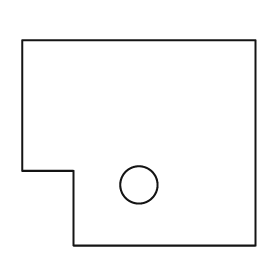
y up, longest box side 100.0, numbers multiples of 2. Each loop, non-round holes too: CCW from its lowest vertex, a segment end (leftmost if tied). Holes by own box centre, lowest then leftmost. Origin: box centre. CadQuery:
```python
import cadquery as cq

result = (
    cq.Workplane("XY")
    .moveTo(-28.0, -44.0)
    .lineTo(50.0, -44.0)
    .lineTo(50.0, 44.0)
    .lineTo(-50.0, 44.0)
    .lineTo(-50.0, -12.0)
    .lineTo(-28.0, -12.0)
    .close()
    .moveTo(0.0, -18.0)
    .circle(8.0)
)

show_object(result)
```